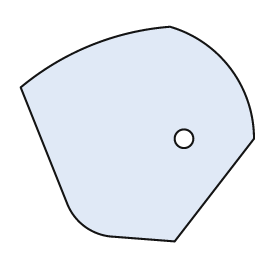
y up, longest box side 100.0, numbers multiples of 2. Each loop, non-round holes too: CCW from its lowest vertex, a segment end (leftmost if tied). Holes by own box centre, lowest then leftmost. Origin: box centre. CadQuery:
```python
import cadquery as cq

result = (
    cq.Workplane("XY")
    .moveTo(16.0, -46.0)
    .lineTo(50.0, -2.0)
    .threePointArc((40.0, 28.0), (14.0, 46.0))
    .threePointArc((-20.0, 38.0), (-50.0, 20.0))
    .lineTo(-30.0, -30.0)
    .threePointArc((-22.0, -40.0), (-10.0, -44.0))
    .close()
    .moveTo(20.0, -2.0)
    .circle(4.0)
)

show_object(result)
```